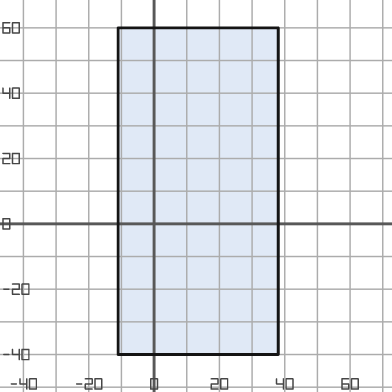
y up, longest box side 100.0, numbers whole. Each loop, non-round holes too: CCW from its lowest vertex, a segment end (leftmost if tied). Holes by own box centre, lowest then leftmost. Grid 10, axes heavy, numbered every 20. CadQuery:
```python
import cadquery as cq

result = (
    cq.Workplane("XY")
    .moveTo(-11.0, -40.0)
    .lineTo(38.0, -40.0)
    .lineTo(38.0, 60.0)
    .lineTo(-11.0, 60.0)
    .close()
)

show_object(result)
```